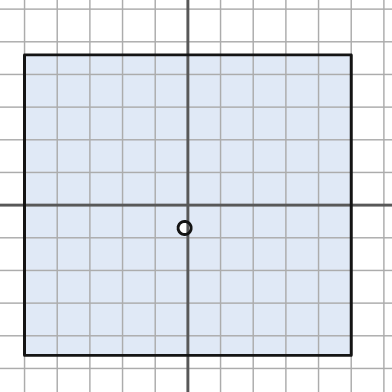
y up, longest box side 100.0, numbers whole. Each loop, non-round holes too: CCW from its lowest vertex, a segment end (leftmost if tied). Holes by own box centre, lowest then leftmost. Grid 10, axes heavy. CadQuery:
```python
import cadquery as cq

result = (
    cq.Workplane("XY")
    .moveTo(-50.0, -46.0)
    .lineTo(50.0, -46.0)
    .lineTo(50.0, 46.0)
    .lineTo(-50.0, 46.0)
    .close()
    .moveTo(-1.0, -7.0)
    .circle(2.0)
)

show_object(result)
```